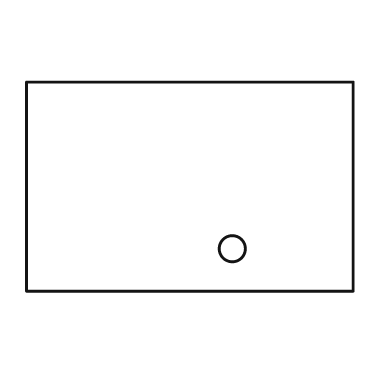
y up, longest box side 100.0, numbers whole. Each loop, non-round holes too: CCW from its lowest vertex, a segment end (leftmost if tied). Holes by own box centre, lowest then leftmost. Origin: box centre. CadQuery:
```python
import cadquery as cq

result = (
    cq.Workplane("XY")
    .moveTo(-50.0, -32.0)
    .lineTo(50.0, -32.0)
    .lineTo(50.0, 32.0)
    .lineTo(-50.0, 32.0)
    .close()
    .moveTo(13.0, -19.0)
    .circle(4.0)
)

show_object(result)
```